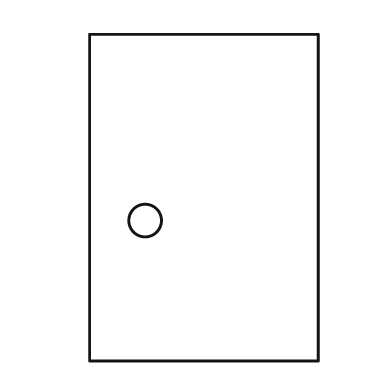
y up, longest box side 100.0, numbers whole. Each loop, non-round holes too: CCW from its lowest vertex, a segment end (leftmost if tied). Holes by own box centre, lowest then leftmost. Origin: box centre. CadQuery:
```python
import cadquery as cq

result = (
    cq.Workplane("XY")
    .moveTo(-35.0, -50.0)
    .lineTo(35.0, -50.0)
    .lineTo(35.0, 50.0)
    .lineTo(-35.0, 50.0)
    .close()
    .moveTo(-18.0, -7.0)
    .circle(5.0)
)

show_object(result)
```